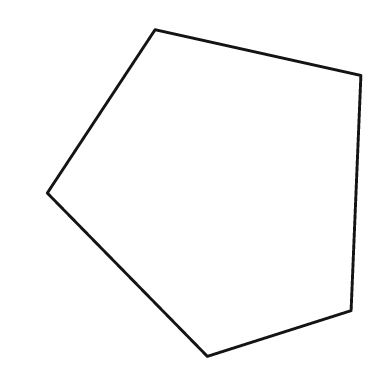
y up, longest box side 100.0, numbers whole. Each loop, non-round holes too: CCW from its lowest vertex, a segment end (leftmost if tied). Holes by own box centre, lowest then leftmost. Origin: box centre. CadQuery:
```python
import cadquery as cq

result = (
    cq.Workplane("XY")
    .moveTo(1.0, -50.0)
    .lineTo(45.0, -36.0)
    .lineTo(48.0, 36.0)
    .lineTo(-15.0, 50.0)
    .lineTo(-48.0, 0.0)
    .close()
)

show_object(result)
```